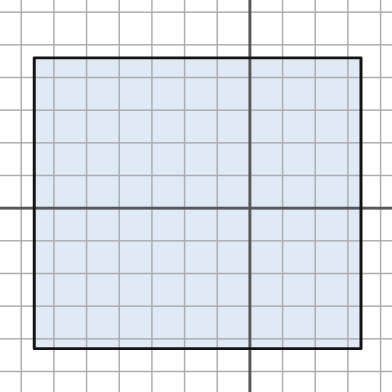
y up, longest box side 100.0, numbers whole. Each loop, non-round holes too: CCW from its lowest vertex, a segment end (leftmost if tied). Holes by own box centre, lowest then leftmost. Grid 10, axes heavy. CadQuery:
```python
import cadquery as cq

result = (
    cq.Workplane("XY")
    .moveTo(-66.0, -43.0)
    .lineTo(34.0, -43.0)
    .lineTo(34.0, 46.0)
    .lineTo(-66.0, 46.0)
    .close()
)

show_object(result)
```